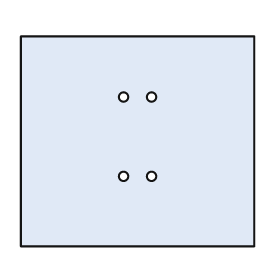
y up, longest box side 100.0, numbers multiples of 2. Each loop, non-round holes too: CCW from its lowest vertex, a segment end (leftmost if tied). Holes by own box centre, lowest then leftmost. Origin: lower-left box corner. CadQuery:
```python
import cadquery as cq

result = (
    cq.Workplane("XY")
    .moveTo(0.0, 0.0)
    .lineTo(100.0, 0.0)
    .lineTo(100.0, 90.0)
    .lineTo(0.0, 90.0)
    .close()
    .moveTo(44.0, 30.0)
    .circle(2.0)
    .moveTo(56.0, 30.0)
    .circle(2.0)
    .moveTo(44.0, 64.0)
    .circle(2.0)
    .moveTo(56.0, 64.0)
    .circle(2.0)
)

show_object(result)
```